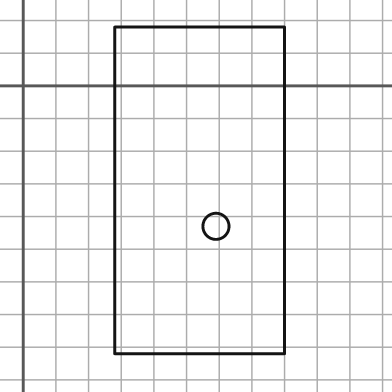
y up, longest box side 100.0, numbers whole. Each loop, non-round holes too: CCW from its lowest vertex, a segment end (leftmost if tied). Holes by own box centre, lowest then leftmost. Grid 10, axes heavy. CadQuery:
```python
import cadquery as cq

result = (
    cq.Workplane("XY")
    .moveTo(28.0, -82.0)
    .lineTo(80.0, -82.0)
    .lineTo(80.0, 18.0)
    .lineTo(28.0, 18.0)
    .close()
    .moveTo(59.0, -43.0)
    .circle(4.0)
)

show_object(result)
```